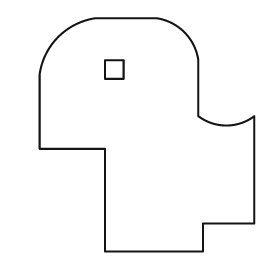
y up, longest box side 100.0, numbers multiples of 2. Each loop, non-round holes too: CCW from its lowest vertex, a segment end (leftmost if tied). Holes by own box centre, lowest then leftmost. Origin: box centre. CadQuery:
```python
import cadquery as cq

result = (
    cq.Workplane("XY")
    .moveTo(-18.0, -50.0)
    .lineTo(24.0, -50.0)
    .lineTo(24.0, -38.0)
    .lineTo(46.0, -38.0)
    .lineTo(46.0, 8.0)
    .threePointArc((34.0, 4.0), (22.0, 8.0))
    .lineTo(22.0, 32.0)
    .threePointArc((16.0, 44.0), (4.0, 50.0))
    .lineTo(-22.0, 50.0)
    .threePointArc((-38.0, 42.0), (-46.0, 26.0))
    .lineTo(-46.0, -6.0)
    .lineTo(-18.0, -6.0)
    .close()
    .moveTo(-18.0, 24.0)
    .lineTo(-10.0, 24.0)
    .lineTo(-10.0, 32.0)
    .lineTo(-18.0, 32.0)
    .close()
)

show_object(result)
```